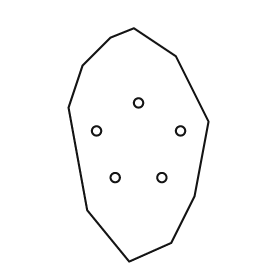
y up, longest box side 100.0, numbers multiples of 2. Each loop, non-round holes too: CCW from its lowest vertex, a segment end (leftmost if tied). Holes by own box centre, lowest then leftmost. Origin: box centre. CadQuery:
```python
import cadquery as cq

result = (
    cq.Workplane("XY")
    .moveTo(-4.0, -50.0)
    .lineTo(14.0, -42.0)
    .lineTo(24.0, -22.0)
    .lineTo(30.0, 10.0)
    .lineTo(16.0, 38.0)
    .lineTo(-2.0, 50.0)
    .lineTo(-12.0, 46.0)
    .lineTo(-24.0, 34.0)
    .lineTo(-30.0, 16.0)
    .lineTo(-22.0, -28.0)
    .close()
    .moveTo(-10.0, -14.0)
    .circle(2.0)
    .moveTo(10.0, -14.0)
    .circle(2.0)
    .moveTo(-18.0, 6.0)
    .circle(2.0)
    .moveTo(18.0, 6.0)
    .circle(2.0)
    .moveTo(0.0, 18.0)
    .circle(2.0)
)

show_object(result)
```